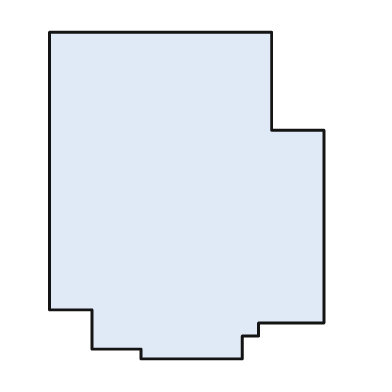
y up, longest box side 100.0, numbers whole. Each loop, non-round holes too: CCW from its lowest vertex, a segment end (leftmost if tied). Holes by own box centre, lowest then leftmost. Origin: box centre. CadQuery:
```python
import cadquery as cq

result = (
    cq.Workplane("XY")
    .moveTo(-14.0, -50.0)
    .lineTo(17.0, -50.0)
    .lineTo(17.0, -43.0)
    .lineTo(22.0, -43.0)
    .lineTo(22.0, -39.0)
    .lineTo(42.0, -39.0)
    .lineTo(42.0, 20.0)
    .lineTo(26.0, 20.0)
    .lineTo(26.0, 50.0)
    .lineTo(-42.0, 50.0)
    .lineTo(-42.0, -35.0)
    .lineTo(-29.0, -35.0)
    .lineTo(-29.0, -47.0)
    .lineTo(-14.0, -47.0)
    .close()
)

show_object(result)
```